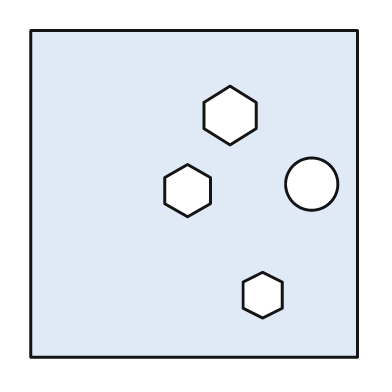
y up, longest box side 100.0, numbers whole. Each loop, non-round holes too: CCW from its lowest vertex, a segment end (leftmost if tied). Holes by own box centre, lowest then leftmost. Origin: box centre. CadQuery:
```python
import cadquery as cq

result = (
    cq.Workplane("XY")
    .moveTo(-50.0, -50.0)
    .lineTo(50.0, -50.0)
    .lineTo(50.0, 50.0)
    .lineTo(-50.0, 50.0)
    .close()
    .moveTo(21.0, -38.0)
    .lineTo(27.0, -35.0)
    .lineTo(27.0, -27.0)
    .lineTo(21.0, -24.0)
    .lineTo(15.0, -27.0)
    .lineTo(15.0, -35.0)
    .close()
    .moveTo(-2.0, -7.0)
    .lineTo(5.0, -3.0)
    .lineTo(5.0, 5.0)
    .lineTo(-2.0, 9.0)
    .lineTo(-9.0, 5.0)
    .lineTo(-9.0, -3.0)
    .close()
    .moveTo(36.0, 3.0)
    .circle(8.0)
    .moveTo(11.0, 15.0)
    .lineTo(19.0, 20.0)
    .lineTo(19.0, 28.0)
    .lineTo(11.0, 33.0)
    .lineTo(3.0, 28.0)
    .lineTo(3.0, 20.0)
    .close()
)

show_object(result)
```